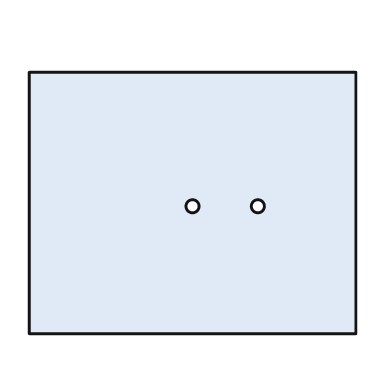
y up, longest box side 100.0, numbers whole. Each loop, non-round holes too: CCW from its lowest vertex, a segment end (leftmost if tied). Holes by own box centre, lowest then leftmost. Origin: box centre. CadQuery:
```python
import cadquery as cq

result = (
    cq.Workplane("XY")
    .moveTo(-50.0, -40.0)
    .lineTo(50.0, -40.0)
    .lineTo(50.0, 40.0)
    .lineTo(-50.0, 40.0)
    .close()
    .moveTo(0.0, -1.0)
    .circle(2.0)
    .moveTo(20.0, -1.0)
    .circle(2.0)
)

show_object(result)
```